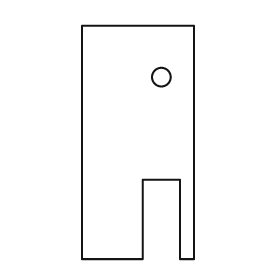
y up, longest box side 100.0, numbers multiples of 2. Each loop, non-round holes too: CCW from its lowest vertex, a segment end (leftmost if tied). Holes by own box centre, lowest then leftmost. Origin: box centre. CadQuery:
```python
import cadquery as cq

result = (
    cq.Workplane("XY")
    .moveTo(-24.0, -50.0)
    .lineTo(2.0, -50.0)
    .lineTo(2.0, -16.0)
    .lineTo(18.0, -16.0)
    .lineTo(18.0, -50.0)
    .lineTo(24.0, -50.0)
    .lineTo(24.0, 50.0)
    .lineTo(-24.0, 50.0)
    .close()
    .moveTo(10.0, 28.0)
    .circle(4.0)
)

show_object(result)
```